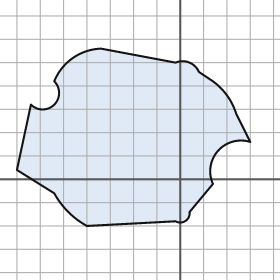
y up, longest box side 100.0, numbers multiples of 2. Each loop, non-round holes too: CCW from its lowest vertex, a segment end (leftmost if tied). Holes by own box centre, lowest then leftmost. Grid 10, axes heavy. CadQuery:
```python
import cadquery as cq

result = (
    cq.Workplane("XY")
    .moveTo(-40.0, -20.0)
    .lineTo(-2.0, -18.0)
    .threePointArc((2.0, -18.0), (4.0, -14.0))
    .lineTo(14.0, -2.0)
    .threePointArc((16.0, 12.0), (30.0, 16.0))
    .lineTo(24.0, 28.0)
    .threePointArc((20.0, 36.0), (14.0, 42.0))
    .lineTo(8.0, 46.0)
    .threePointArc((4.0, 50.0), (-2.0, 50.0))
    .lineTo(-34.0, 56.0)
    .threePointArc((-46.0, 52.0), (-54.0, 42.0))
    .threePointArc((-54.0, 32.0), (-64.0, 32.0))
    .lineTo(-70.0, 4.0)
    .lineTo(-54.0, -6.0)
    .threePointArc((-48.0, -14.0), (-40.0, -20.0))
    .close()
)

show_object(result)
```